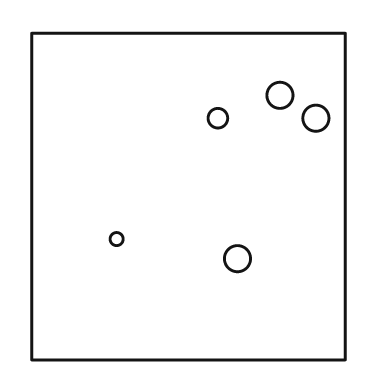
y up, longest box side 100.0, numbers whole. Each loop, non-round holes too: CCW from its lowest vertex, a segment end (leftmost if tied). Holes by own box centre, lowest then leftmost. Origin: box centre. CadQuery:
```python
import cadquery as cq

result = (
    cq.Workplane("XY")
    .moveTo(-48.0, -50.0)
    .lineTo(48.0, -50.0)
    .lineTo(48.0, 50.0)
    .lineTo(-48.0, 50.0)
    .close()
    .moveTo(15.0, -19.0)
    .circle(4.0)
    .moveTo(-22.0, -13.0)
    .circle(2.0)
    .moveTo(9.0, 24.0)
    .circle(3.0)
    .moveTo(39.0, 24.0)
    .circle(4.0)
    .moveTo(28.0, 31.0)
    .circle(4.0)
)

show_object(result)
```